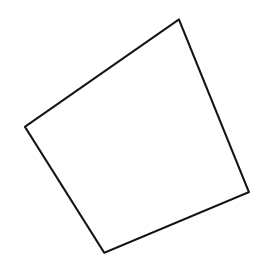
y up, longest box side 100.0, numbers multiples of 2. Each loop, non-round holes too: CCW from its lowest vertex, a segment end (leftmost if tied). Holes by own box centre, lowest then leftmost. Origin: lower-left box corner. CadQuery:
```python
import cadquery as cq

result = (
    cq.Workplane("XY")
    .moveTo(34.0, 0.0)
    .lineTo(96.0, 26.0)
    .lineTo(66.0, 100.0)
    .lineTo(0.0, 54.0)
    .close()
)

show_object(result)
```